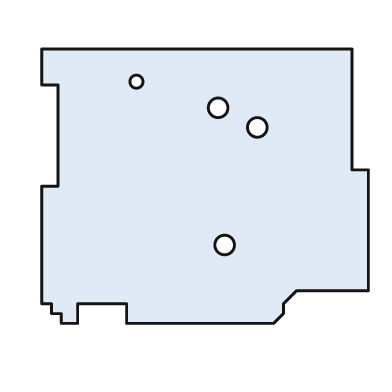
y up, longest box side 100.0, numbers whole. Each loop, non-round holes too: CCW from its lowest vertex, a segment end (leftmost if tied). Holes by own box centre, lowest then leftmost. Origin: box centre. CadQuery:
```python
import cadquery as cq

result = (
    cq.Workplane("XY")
    .moveTo(-44.0, -42.0)
    .lineTo(-39.0, -42.0)
    .lineTo(-39.0, -36.0)
    .lineTo(-24.0, -36.0)
    .lineTo(-24.0, -42.0)
    .lineTo(21.0, -42.0)
    .lineTo(24.0, -39.0)
    .lineTo(24.0, -36.0)
    .lineTo(28.0, -32.0)
    .lineTo(50.0, -32.0)
    .lineTo(50.0, 5.0)
    .lineTo(45.0, 5.0)
    .lineTo(45.0, 42.0)
    .lineTo(-50.0, 42.0)
    .lineTo(-50.0, 31.0)
    .lineTo(-45.0, 31.0)
    .lineTo(-45.0, 0.0)
    .lineTo(-50.0, 0.0)
    .lineTo(-50.0, -36.0)
    .lineTo(-47.0, -36.0)
    .lineTo(-47.0, -39.0)
    .lineTo(-44.0, -39.0)
    .close()
    .moveTo(6.0, -18.0)
    .circle(3.0)
    .moveTo(16.0, 18.0)
    .circle(3.0)
    .moveTo(4.0, 24.0)
    .circle(3.0)
    .moveTo(-21.0, 32.0)
    .circle(2.0)
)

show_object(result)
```